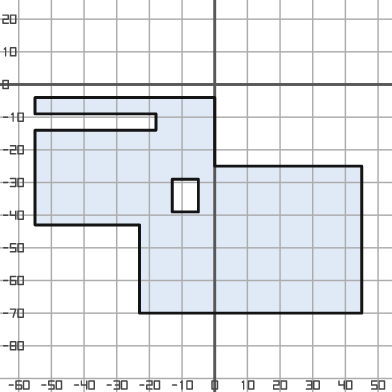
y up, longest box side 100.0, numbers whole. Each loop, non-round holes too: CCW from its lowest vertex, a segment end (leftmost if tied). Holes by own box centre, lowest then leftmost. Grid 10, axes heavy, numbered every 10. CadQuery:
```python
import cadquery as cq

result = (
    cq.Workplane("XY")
    .moveTo(-23.0, -70.0)
    .lineTo(45.0, -70.0)
    .lineTo(45.0, -25.0)
    .lineTo(0.0, -25.0)
    .lineTo(0.0, -4.0)
    .lineTo(-55.0, -4.0)
    .lineTo(-55.0, -9.0)
    .lineTo(-18.0, -9.0)
    .lineTo(-18.0, -14.0)
    .lineTo(-55.0, -14.0)
    .lineTo(-55.0, -43.0)
    .lineTo(-23.0, -43.0)
    .close()
    .moveTo(-13.0, -39.0)
    .lineTo(-5.0, -39.0)
    .lineTo(-5.0, -29.0)
    .lineTo(-13.0, -29.0)
    .close()
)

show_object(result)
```